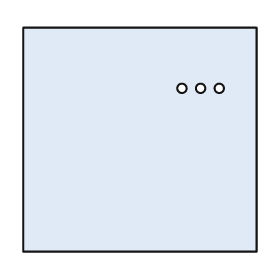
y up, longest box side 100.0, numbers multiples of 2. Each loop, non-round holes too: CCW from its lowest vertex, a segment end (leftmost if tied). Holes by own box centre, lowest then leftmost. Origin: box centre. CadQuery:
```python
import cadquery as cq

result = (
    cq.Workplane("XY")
    .moveTo(-50.0, -48.0)
    .lineTo(50.0, -48.0)
    .lineTo(50.0, 48.0)
    .lineTo(-50.0, 48.0)
    .close()
    .moveTo(18.0, 22.0)
    .circle(2.0)
    .moveTo(26.0, 22.0)
    .circle(2.0)
    .moveTo(34.0, 22.0)
    .circle(2.0)
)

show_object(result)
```